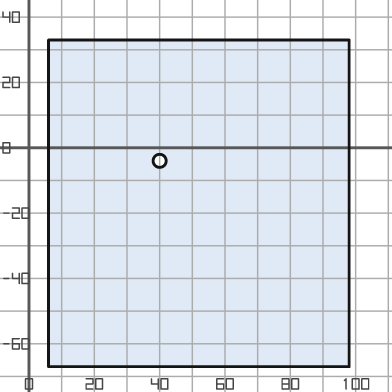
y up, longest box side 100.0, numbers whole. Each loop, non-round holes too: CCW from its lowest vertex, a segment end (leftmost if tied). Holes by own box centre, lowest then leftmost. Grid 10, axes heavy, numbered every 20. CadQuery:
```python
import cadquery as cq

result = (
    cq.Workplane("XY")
    .moveTo(6.0, -67.0)
    .lineTo(98.0, -67.0)
    .lineTo(98.0, 33.0)
    .lineTo(6.0, 33.0)
    .close()
    .moveTo(40.0, -4.0)
    .circle(2.0)
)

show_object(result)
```